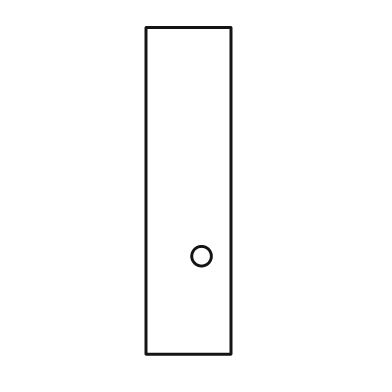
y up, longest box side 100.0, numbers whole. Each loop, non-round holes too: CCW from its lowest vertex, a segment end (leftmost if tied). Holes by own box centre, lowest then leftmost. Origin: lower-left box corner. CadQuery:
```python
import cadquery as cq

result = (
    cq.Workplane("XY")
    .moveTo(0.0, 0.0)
    .lineTo(26.0, 0.0)
    .lineTo(26.0, 100.0)
    .lineTo(0.0, 100.0)
    .close()
    .moveTo(17.0, 30.0)
    .circle(3.0)
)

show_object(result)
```